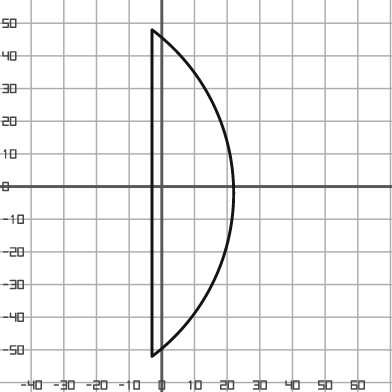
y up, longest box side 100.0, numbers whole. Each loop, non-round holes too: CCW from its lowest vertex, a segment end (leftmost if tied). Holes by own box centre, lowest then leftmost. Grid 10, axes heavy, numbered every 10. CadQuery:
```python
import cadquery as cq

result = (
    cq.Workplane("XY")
    .moveTo(-3.0, -52.0)
    .threePointArc((22.0, -2.0), (-3.0, 48.0))
    .close()
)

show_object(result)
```